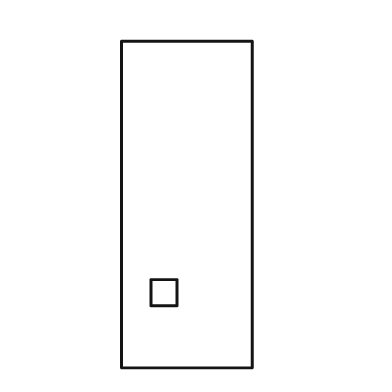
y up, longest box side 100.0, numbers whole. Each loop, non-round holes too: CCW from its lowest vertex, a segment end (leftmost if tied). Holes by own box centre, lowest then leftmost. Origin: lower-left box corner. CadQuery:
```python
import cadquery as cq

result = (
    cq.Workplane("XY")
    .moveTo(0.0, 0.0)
    .lineTo(40.0, 0.0)
    .lineTo(40.0, 100.0)
    .lineTo(0.0, 100.0)
    .close()
    .moveTo(9.0, 19.0)
    .lineTo(17.0, 19.0)
    .lineTo(17.0, 27.0)
    .lineTo(9.0, 27.0)
    .close()
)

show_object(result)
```